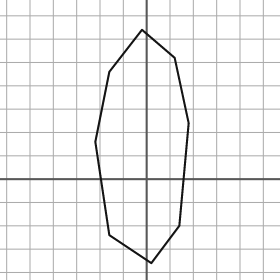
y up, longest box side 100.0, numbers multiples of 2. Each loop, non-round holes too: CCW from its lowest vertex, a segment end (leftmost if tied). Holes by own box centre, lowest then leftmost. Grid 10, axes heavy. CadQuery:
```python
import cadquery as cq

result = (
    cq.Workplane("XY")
    .moveTo(2.0, -36.0)
    .lineTo(14.0, -20.0)
    .lineTo(18.0, 24.0)
    .lineTo(12.0, 52.0)
    .lineTo(-2.0, 64.0)
    .lineTo(-16.0, 46.0)
    .lineTo(-22.0, 16.0)
    .lineTo(-16.0, -24.0)
    .close()
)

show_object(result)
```